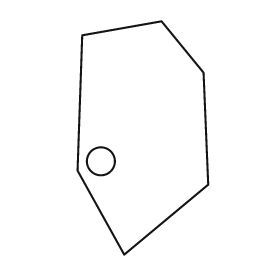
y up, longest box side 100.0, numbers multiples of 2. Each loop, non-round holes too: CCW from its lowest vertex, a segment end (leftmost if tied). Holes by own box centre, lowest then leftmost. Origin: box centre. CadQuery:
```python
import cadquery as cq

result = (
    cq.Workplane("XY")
    .moveTo(-8.0, -50.0)
    .lineTo(28.0, -20.0)
    .lineTo(26.0, 28.0)
    .lineTo(8.0, 50.0)
    .lineTo(-26.0, 44.0)
    .lineTo(-28.0, -14.0)
    .close()
    .moveTo(-18.0, -10.0)
    .circle(6.0)
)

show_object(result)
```